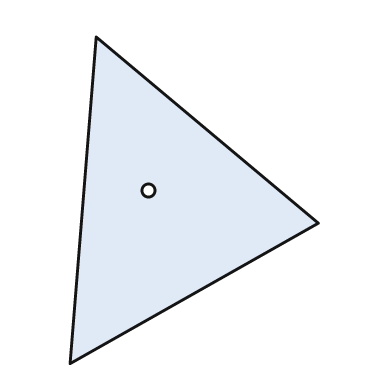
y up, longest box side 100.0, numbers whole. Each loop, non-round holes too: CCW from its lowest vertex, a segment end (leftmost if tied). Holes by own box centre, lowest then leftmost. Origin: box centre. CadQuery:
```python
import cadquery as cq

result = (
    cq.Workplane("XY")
    .moveTo(-38.0, -50.0)
    .lineTo(38.0, -7.0)
    .lineTo(-30.0, 50.0)
    .close()
    .moveTo(-14.0, 3.0)
    .circle(2.0)
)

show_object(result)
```